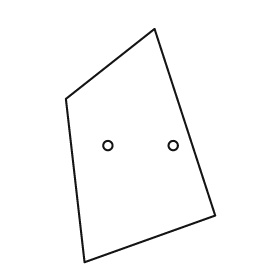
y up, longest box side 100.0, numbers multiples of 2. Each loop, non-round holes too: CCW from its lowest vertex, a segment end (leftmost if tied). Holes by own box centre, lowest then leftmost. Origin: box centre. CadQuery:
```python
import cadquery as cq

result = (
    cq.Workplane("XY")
    .moveTo(-24.0, -50.0)
    .lineTo(32.0, -30.0)
    .lineTo(6.0, 50.0)
    .lineTo(-32.0, 20.0)
    .close()
    .moveTo(-14.0, 0.0)
    .circle(2.0)
    .moveTo(14.0, 0.0)
    .circle(2.0)
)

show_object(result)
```